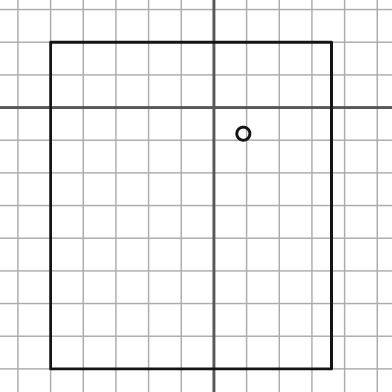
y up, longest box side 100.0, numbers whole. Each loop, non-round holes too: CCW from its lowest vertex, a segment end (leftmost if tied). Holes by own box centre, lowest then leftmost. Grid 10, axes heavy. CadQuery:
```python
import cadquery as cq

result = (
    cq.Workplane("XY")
    .moveTo(-50.0, -80.0)
    .lineTo(36.0, -80.0)
    .lineTo(36.0, 20.0)
    .lineTo(-50.0, 20.0)
    .close()
    .moveTo(9.0, -8.0)
    .circle(2.0)
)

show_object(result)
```